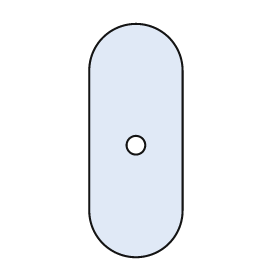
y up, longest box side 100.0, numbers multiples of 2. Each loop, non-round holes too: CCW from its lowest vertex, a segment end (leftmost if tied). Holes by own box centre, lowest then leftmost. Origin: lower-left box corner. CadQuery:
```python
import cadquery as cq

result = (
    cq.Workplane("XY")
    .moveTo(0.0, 20.0)
    .threePointArc((20.0, 0.0), (40.0, 20.0))
    .lineTo(40.0, 80.0)
    .threePointArc((20.0, 100.0), (0.0, 80.0))
    .close()
    .moveTo(20.0, 48.0)
    .circle(4.0)
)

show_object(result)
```